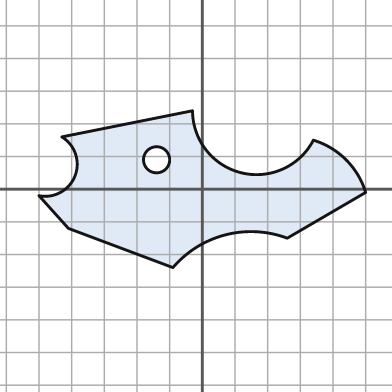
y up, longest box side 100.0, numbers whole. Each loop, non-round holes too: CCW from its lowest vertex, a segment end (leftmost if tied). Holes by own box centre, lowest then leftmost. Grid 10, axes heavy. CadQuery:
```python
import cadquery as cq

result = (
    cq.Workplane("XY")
    .moveTo(-9.0, -24.0)
    .threePointArc((7.0, -14.0), (26.0, -15.0))
    .lineTo(50.0, -1.0)
    .threePointArc((44.0, 9.0), (34.0, 15.0))
    .threePointArc((12.0, 5.0), (-3.0, 24.0))
    .lineTo(-43.0, 16.0)
    .threePointArc((-39.0, 4.0), (-50.0, -2.0))
    .lineTo(-41.0, -12.0)
    .close()
    .moveTo(-14.0, 9.0)
    .circle(4.0)
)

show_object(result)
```